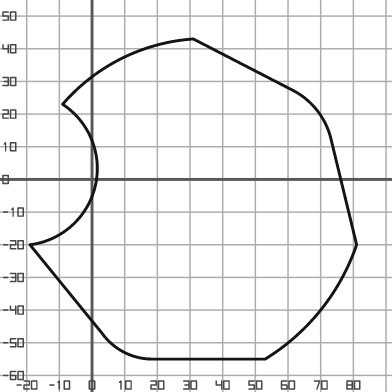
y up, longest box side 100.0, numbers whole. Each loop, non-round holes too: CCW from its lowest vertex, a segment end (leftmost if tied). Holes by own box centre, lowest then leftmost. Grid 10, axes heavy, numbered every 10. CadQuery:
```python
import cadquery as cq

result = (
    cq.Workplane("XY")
    .moveTo(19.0, -55.0)
    .lineTo(53.0, -55.0)
    .threePointArc((70.0, -40.0), (81.0, -20.0))
    .lineTo(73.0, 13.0)
    .threePointArc((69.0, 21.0), (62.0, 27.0))
    .lineTo(31.0, 43.0)
    .threePointArc((9.0, 37.0), (-9.0, 23.0))
    .threePointArc((1.0, -2.0), (-19.0, -20.0))
    .lineTo(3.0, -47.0)
    .threePointArc((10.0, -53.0), (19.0, -55.0))
    .close()
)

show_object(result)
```